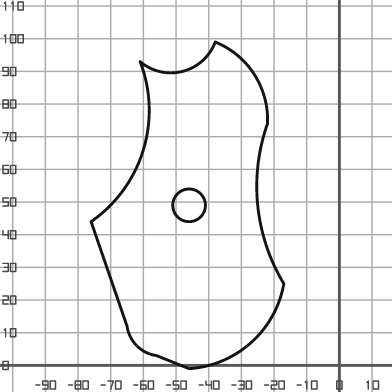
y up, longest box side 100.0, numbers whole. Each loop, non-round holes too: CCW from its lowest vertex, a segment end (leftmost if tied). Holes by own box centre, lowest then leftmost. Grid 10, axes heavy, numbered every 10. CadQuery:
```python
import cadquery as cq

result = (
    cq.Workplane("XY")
    .moveTo(-46.0, -1.0)
    .threePointArc((-27.0, 7.0), (-17.0, 25.0))
    .threePointArc((-25.0, 49.0), (-22.0, 74.0))
    .threePointArc((-26.0, 89.0), (-38.0, 99.0))
    .threePointArc((-48.0, 90.0), (-61.0, 93.0))
    .threePointArc((-60.0, 66.0), (-76.0, 44.0))
    .lineTo(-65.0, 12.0)
    .threePointArc((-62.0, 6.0), (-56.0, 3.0))
    .close()
    .moveTo(-46.0, 49.0)
    .circle(5.0)
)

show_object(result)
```